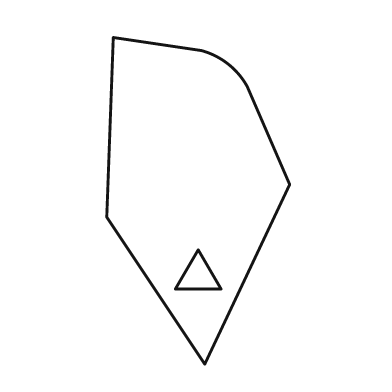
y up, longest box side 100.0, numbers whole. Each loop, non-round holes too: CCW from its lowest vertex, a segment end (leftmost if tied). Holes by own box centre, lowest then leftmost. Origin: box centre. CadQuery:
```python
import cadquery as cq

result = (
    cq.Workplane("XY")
    .moveTo(2.0, -50.0)
    .lineTo(28.0, 5.0)
    .lineTo(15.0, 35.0)
    .threePointArc((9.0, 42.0), (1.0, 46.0))
    .lineTo(-26.0, 50.0)
    .lineTo(-28.0, -5.0)
    .close()
    .moveTo(-7.0, -27.0)
    .lineTo(7.0, -27.0)
    .lineTo(0.0, -15.0)
    .close()
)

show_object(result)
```